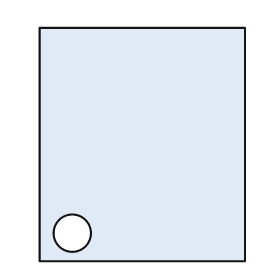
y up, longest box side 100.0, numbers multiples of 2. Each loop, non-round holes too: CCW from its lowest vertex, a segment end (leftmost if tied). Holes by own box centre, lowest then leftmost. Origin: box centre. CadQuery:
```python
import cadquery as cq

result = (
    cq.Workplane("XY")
    .moveTo(-44.0, -50.0)
    .lineTo(44.0, -50.0)
    .lineTo(44.0, 50.0)
    .lineTo(-44.0, 50.0)
    .close()
    .moveTo(-30.0, -38.0)
    .circle(8.0)
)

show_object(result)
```